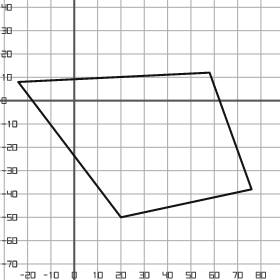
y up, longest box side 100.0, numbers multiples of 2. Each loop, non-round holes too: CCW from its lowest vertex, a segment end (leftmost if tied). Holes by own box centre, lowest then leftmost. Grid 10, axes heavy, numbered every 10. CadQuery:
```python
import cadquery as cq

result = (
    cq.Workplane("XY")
    .moveTo(20.0, -50.0)
    .lineTo(76.0, -38.0)
    .lineTo(58.0, 12.0)
    .lineTo(-24.0, 8.0)
    .close()
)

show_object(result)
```